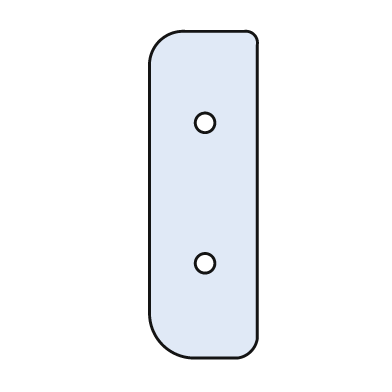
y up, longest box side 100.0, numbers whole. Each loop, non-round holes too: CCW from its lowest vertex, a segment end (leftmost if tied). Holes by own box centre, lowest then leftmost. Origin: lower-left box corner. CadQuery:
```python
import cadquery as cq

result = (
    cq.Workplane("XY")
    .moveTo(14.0, 0.0)
    .lineTo(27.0, 0.0)
    .threePointArc((31.0, 2.0), (33.0, 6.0))
    .lineTo(33.0, 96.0)
    .threePointArc((32.0, 99.0), (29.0, 100.0))
    .lineTo(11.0, 100.0)
    .threePointArc((3.0, 97.0), (0.0, 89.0))
    .lineTo(0.0, 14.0)
    .threePointArc((4.0, 4.0), (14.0, 0.0))
    .close()
    .moveTo(17.0, 29.0)
    .circle(3.0)
    .moveTo(17.0, 72.0)
    .circle(3.0)
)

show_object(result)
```